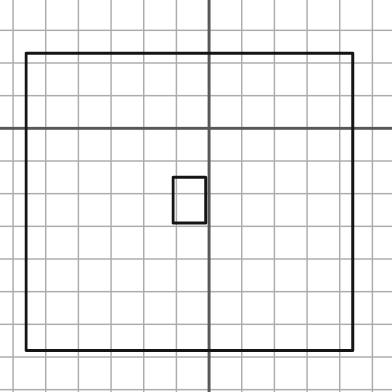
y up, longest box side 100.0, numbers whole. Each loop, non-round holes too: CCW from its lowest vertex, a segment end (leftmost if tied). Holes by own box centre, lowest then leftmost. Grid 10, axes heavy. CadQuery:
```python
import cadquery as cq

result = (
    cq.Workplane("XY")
    .moveTo(-56.0, -68.0)
    .lineTo(44.0, -68.0)
    .lineTo(44.0, 23.0)
    .lineTo(-56.0, 23.0)
    .close()
    .moveTo(-11.0, -29.0)
    .lineTo(-1.0, -29.0)
    .lineTo(-1.0, -15.0)
    .lineTo(-11.0, -15.0)
    .close()
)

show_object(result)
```